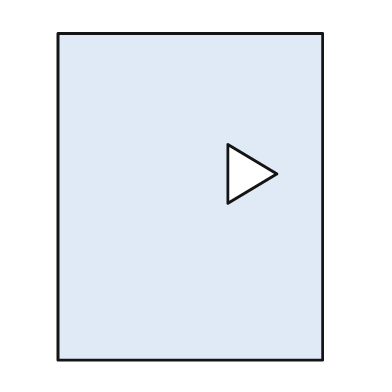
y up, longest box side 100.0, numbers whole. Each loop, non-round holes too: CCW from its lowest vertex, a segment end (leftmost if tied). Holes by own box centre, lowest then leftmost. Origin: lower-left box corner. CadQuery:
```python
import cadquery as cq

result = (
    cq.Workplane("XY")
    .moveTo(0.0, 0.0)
    .lineTo(81.0, 0.0)
    .lineTo(81.0, 100.0)
    .lineTo(0.0, 100.0)
    .close()
    .moveTo(52.0, 48.0)
    .lineTo(67.0, 57.0)
    .lineTo(52.0, 66.0)
    .close()
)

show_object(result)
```